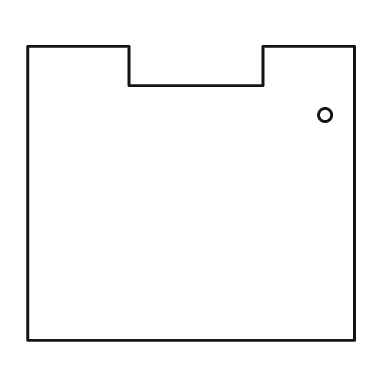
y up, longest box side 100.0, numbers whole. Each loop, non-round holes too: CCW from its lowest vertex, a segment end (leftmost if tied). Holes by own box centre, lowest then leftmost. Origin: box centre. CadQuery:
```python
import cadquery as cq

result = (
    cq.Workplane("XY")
    .moveTo(-50.0, -45.0)
    .lineTo(50.0, -45.0)
    .lineTo(50.0, 45.0)
    .lineTo(22.0, 45.0)
    .lineTo(22.0, 33.0)
    .lineTo(-19.0, 33.0)
    .lineTo(-19.0, 45.0)
    .lineTo(-50.0, 45.0)
    .close()
    .moveTo(41.0, 24.0)
    .circle(2.0)
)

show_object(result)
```